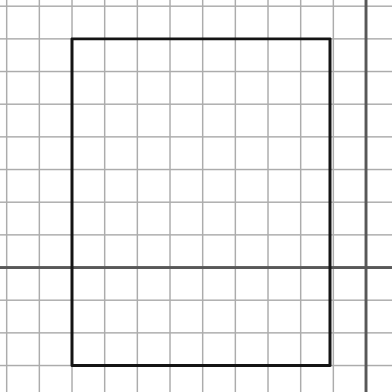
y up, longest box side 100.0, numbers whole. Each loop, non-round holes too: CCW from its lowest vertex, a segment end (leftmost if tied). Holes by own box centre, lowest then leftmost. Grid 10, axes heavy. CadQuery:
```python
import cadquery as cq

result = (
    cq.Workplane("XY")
    .moveTo(-90.0, -30.0)
    .lineTo(-11.0, -30.0)
    .lineTo(-11.0, 70.0)
    .lineTo(-90.0, 70.0)
    .close()
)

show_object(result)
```